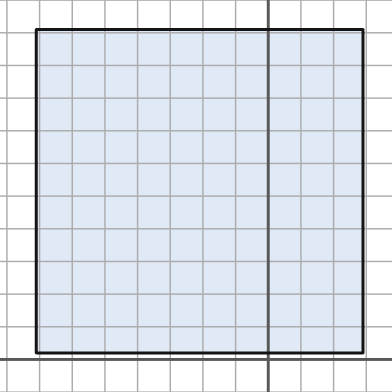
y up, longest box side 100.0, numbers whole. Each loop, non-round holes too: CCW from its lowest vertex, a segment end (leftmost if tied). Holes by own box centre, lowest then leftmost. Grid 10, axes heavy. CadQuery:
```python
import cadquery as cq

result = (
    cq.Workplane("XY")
    .moveTo(-71.0, 2.0)
    .lineTo(29.0, 2.0)
    .lineTo(29.0, 101.0)
    .lineTo(-71.0, 101.0)
    .close()
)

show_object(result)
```